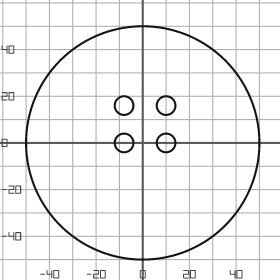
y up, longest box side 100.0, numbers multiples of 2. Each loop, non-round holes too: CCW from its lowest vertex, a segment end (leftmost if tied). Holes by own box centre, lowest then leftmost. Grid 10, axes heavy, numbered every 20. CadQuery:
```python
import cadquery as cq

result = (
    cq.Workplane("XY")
    .moveTo(0.0, 0.0)
    .circle(50.0)
    .moveTo(-8.0, 0.0)
    .circle(4.0)
    .moveTo(10.0, 0.0)
    .circle(4.0)
    .moveTo(-8.0, 16.0)
    .circle(4.0)
    .moveTo(10.0, 16.0)
    .circle(4.0)
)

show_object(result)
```